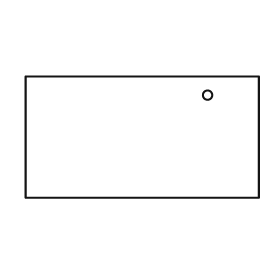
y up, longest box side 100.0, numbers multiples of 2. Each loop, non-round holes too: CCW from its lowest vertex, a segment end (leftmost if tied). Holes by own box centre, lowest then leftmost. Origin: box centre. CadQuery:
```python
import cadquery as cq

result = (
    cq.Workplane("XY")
    .moveTo(-50.0, -26.0)
    .lineTo(50.0, -26.0)
    .lineTo(50.0, 26.0)
    .lineTo(-50.0, 26.0)
    .close()
    .moveTo(28.0, 18.0)
    .circle(2.0)
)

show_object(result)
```